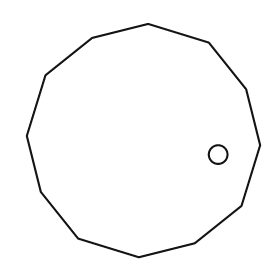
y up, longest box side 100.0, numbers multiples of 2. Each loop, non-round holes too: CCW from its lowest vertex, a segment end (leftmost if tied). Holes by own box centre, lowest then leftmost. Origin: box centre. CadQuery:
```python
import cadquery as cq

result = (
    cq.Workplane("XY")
    .moveTo(-2.0, -50.0)
    .lineTo(22.0, -44.0)
    .lineTo(42.0, -28.0)
    .lineTo(50.0, -2.0)
    .lineTo(44.0, 22.0)
    .lineTo(28.0, 42.0)
    .lineTo(2.0, 50.0)
    .lineTo(-22.0, 44.0)
    .lineTo(-42.0, 28.0)
    .lineTo(-50.0, 2.0)
    .lineTo(-44.0, -22.0)
    .lineTo(-28.0, -42.0)
    .close()
    .moveTo(32.0, -6.0)
    .circle(4.0)
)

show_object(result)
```